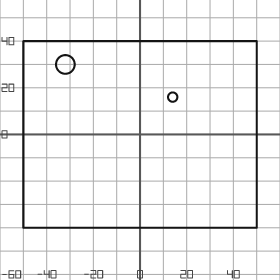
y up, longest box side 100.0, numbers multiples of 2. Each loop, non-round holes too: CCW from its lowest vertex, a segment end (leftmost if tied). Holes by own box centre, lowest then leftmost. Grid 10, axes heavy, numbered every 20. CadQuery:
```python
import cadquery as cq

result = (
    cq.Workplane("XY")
    .moveTo(-50.0, -40.0)
    .lineTo(50.0, -40.0)
    .lineTo(50.0, 40.0)
    .lineTo(-50.0, 40.0)
    .close()
    .moveTo(14.0, 16.0)
    .circle(2.0)
    .moveTo(-32.0, 30.0)
    .circle(4.0)
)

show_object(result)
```